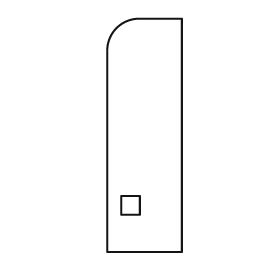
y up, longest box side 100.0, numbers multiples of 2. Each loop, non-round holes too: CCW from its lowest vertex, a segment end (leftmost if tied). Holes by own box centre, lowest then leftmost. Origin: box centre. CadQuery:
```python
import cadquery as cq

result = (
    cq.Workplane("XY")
    .moveTo(-16.0, -50.0)
    .lineTo(16.0, -50.0)
    .lineTo(16.0, 50.0)
    .lineTo(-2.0, 50.0)
    .threePointArc((-12.0, 46.0), (-16.0, 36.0))
    .close()
    .moveTo(-10.0, -34.0)
    .lineTo(-2.0, -34.0)
    .lineTo(-2.0, -26.0)
    .lineTo(-10.0, -26.0)
    .close()
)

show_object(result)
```